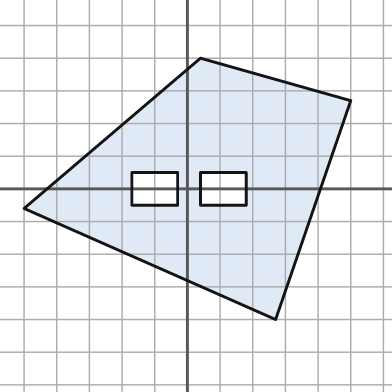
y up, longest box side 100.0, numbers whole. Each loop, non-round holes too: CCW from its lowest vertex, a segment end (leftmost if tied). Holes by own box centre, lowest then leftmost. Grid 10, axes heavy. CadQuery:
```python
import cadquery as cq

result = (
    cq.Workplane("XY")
    .moveTo(27.0, -40.0)
    .lineTo(50.0, 27.0)
    .lineTo(4.0, 40.0)
    .lineTo(-50.0, -6.0)
    .close()
    .moveTo(-17.0, -5.0)
    .lineTo(-3.0, -5.0)
    .lineTo(-3.0, 5.0)
    .lineTo(-17.0, 5.0)
    .close()
    .moveTo(4.0, -5.0)
    .lineTo(18.0, -5.0)
    .lineTo(18.0, 5.0)
    .lineTo(4.0, 5.0)
    .close()
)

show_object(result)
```